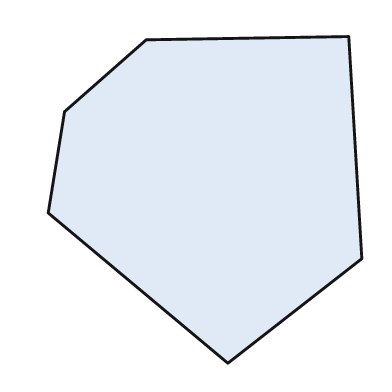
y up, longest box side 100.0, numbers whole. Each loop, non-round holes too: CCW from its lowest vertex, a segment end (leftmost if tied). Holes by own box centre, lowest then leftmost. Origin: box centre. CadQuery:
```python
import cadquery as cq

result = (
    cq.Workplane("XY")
    .moveTo(7.0, -50.0)
    .lineTo(48.0, -18.0)
    .lineTo(44.0, 50.0)
    .lineTo(-18.0, 49.0)
    .lineTo(-43.0, 27.0)
    .lineTo(-48.0, -4.0)
    .close()
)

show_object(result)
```